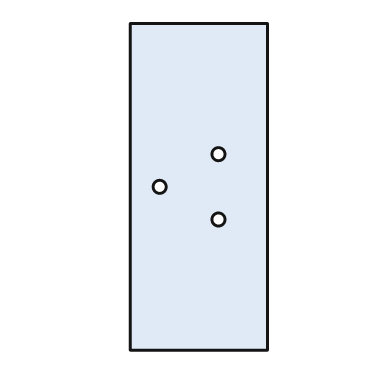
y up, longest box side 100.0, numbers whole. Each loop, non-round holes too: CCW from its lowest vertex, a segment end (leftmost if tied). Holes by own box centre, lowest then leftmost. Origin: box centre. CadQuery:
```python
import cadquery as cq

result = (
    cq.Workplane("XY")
    .moveTo(-21.0, -50.0)
    .lineTo(21.0, -50.0)
    .lineTo(21.0, 50.0)
    .lineTo(-21.0, 50.0)
    .close()
    .moveTo(6.0, -10.0)
    .circle(2.0)
    .moveTo(-12.0, 0.0)
    .circle(2.0)
    .moveTo(6.0, 10.0)
    .circle(2.0)
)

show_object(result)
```